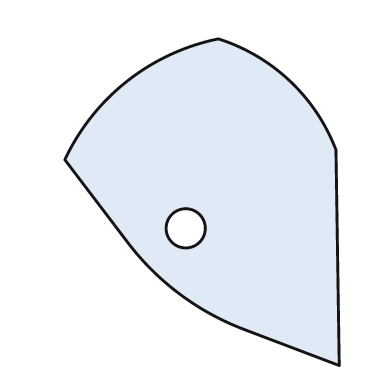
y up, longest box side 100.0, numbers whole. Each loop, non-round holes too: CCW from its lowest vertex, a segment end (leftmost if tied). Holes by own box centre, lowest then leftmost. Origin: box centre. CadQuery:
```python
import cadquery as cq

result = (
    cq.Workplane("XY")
    .moveTo(42.0, -50.0)
    .lineTo(41.0, 16.0)
    .threePointArc((27.0, 37.0), (5.0, 50.0))
    .threePointArc((-23.0, 37.0), (-42.0, 13.0))
    .lineTo(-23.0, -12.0)
    .threePointArc((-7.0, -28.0), (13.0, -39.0))
    .close()
    .moveTo(-5.0, -8.0)
    .circle(6.0)
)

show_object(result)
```